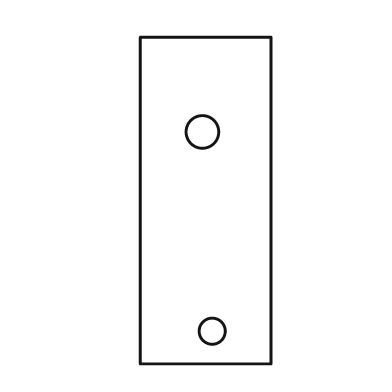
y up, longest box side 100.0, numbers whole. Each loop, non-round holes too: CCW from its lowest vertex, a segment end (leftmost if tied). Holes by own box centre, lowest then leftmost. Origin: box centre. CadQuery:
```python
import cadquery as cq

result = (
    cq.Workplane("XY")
    .moveTo(-20.0, -50.0)
    .lineTo(20.0, -50.0)
    .lineTo(20.0, 50.0)
    .lineTo(-20.0, 50.0)
    .close()
    .moveTo(2.0, -40.0)
    .circle(4.0)
    .moveTo(-1.0, 21.0)
    .circle(5.0)
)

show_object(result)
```